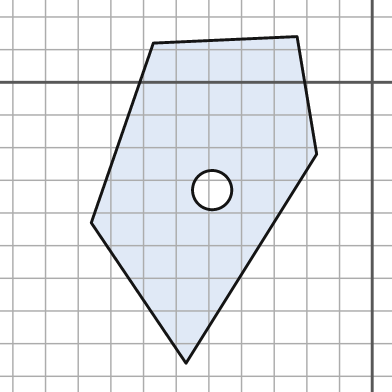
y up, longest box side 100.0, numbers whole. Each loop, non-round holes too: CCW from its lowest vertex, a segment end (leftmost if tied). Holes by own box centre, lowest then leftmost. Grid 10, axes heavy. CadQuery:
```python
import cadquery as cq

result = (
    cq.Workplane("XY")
    .moveTo(-57.0, -86.0)
    .lineTo(-17.0, -22.0)
    .lineTo(-23.0, 14.0)
    .lineTo(-67.0, 12.0)
    .lineTo(-86.0, -43.0)
    .close()
    .moveTo(-49.0, -33.0)
    .circle(6.0)
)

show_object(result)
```